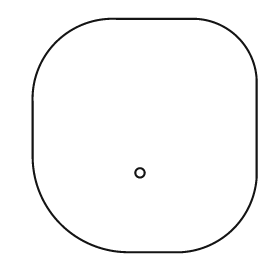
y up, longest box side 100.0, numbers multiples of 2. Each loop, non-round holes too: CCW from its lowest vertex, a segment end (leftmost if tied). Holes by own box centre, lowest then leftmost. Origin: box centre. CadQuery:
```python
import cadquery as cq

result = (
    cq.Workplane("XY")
    .moveTo(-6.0, -50.0)
    .lineTo(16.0, -50.0)
    .threePointArc((38.0, -40.0), (48.0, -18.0))
    .lineTo(48.0, 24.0)
    .threePointArc((40.0, 42.0), (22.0, 50.0))
    .lineTo(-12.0, 50.0)
    .threePointArc((-38.0, 40.0), (-48.0, 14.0))
    .lineTo(-48.0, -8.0)
    .threePointArc((-36.0, -38.0), (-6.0, -50.0))
    .close()
    .moveTo(-2.0, -16.0)
    .circle(2.0)
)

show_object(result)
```